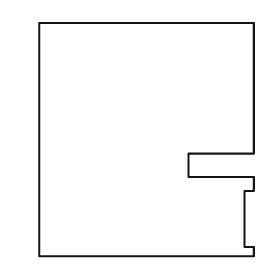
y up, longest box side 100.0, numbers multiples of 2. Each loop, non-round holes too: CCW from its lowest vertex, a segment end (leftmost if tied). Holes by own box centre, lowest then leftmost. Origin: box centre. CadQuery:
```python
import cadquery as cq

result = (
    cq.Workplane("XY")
    .moveTo(-46.0, -50.0)
    .lineTo(46.0, -50.0)
    .lineTo(46.0, -46.0)
    .lineTo(42.0, -46.0)
    .lineTo(42.0, -22.0)
    .lineTo(46.0, -22.0)
    .lineTo(46.0, -16.0)
    .lineTo(18.0, -16.0)
    .lineTo(18.0, -6.0)
    .lineTo(46.0, -6.0)
    .lineTo(46.0, 50.0)
    .lineTo(-46.0, 50.0)
    .close()
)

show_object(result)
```